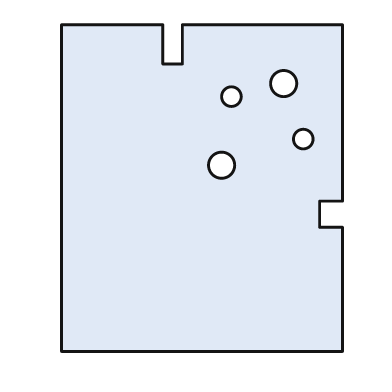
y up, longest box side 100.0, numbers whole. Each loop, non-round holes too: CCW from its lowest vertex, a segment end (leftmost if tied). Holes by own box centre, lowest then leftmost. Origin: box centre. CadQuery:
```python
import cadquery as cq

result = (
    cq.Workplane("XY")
    .moveTo(-43.0, -50.0)
    .lineTo(43.0, -50.0)
    .lineTo(43.0, -12.0)
    .lineTo(36.0, -12.0)
    .lineTo(36.0, -4.0)
    .lineTo(43.0, -4.0)
    .lineTo(43.0, 50.0)
    .lineTo(-6.0, 50.0)
    .lineTo(-6.0, 38.0)
    .lineTo(-12.0, 38.0)
    .lineTo(-12.0, 50.0)
    .lineTo(-43.0, 50.0)
    .close()
    .moveTo(6.0, 7.0)
    .circle(4.0)
    .moveTo(31.0, 15.0)
    .circle(3.0)
    .moveTo(9.0, 28.0)
    .circle(3.0)
    .moveTo(25.0, 32.0)
    .circle(4.0)
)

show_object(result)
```